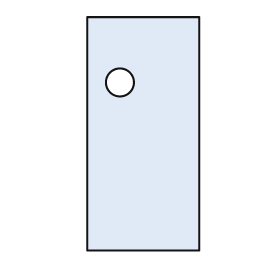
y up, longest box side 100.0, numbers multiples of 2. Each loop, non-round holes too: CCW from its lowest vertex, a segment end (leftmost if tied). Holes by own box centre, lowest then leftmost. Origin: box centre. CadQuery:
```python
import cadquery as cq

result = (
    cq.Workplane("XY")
    .moveTo(-24.0, -50.0)
    .lineTo(24.0, -50.0)
    .lineTo(24.0, 50.0)
    .lineTo(-24.0, 50.0)
    .close()
    .moveTo(-10.0, 22.0)
    .circle(6.0)
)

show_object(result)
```